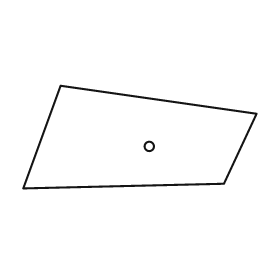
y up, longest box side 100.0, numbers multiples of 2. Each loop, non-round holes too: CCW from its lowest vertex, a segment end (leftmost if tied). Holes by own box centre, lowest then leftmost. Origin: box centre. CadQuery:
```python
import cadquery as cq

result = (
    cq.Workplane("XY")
    .moveTo(-50.0, -22.0)
    .lineTo(36.0, -20.0)
    .lineTo(50.0, 10.0)
    .lineTo(-34.0, 22.0)
    .close()
    .moveTo(4.0, -4.0)
    .circle(2.0)
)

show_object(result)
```